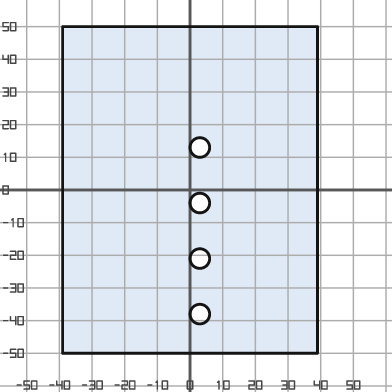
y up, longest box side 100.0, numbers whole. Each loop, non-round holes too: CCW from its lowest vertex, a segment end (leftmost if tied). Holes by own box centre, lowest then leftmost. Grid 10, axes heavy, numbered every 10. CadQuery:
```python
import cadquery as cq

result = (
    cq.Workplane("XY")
    .moveTo(-39.0, -50.0)
    .lineTo(39.0, -50.0)
    .lineTo(39.0, 50.0)
    .lineTo(-39.0, 50.0)
    .close()
    .moveTo(3.0, -38.0)
    .circle(3.0)
    .moveTo(3.0, -21.0)
    .circle(3.0)
    .moveTo(3.0, -4.0)
    .circle(3.0)
    .moveTo(3.0, 13.0)
    .circle(3.0)
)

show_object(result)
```